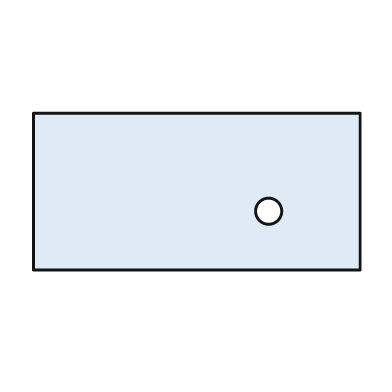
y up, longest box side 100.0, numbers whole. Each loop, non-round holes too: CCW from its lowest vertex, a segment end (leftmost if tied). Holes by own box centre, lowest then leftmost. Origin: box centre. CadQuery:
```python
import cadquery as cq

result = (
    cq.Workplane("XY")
    .moveTo(-50.0, -24.0)
    .lineTo(50.0, -24.0)
    .lineTo(50.0, 24.0)
    .lineTo(-50.0, 24.0)
    .close()
    .moveTo(22.0, -6.0)
    .circle(4.0)
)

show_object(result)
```